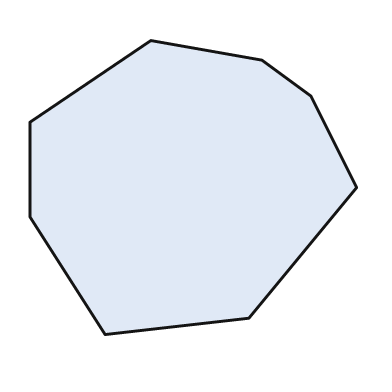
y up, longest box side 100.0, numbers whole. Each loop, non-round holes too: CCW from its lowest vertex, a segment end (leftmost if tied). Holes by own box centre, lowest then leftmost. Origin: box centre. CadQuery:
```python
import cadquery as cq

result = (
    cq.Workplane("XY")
    .moveTo(-27.0, -45.0)
    .lineTo(17.0, -40.0)
    .lineTo(50.0, 0.0)
    .lineTo(36.0, 28.0)
    .lineTo(21.0, 39.0)
    .lineTo(-13.0, 45.0)
    .lineTo(-50.0, 20.0)
    .lineTo(-50.0, -9.0)
    .close()
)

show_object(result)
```